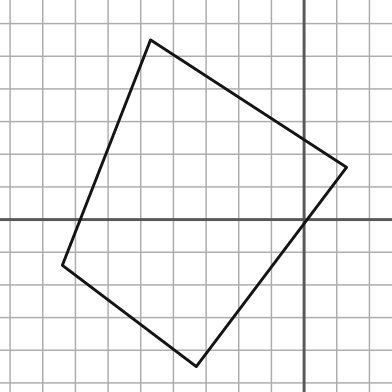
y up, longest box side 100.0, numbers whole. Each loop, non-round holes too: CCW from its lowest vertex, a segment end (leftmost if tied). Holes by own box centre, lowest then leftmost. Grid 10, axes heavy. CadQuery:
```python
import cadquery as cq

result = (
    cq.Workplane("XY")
    .moveTo(-33.0, -45.0)
    .lineTo(13.0, 16.0)
    .lineTo(-47.0, 55.0)
    .lineTo(-74.0, -14.0)
    .close()
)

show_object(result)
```